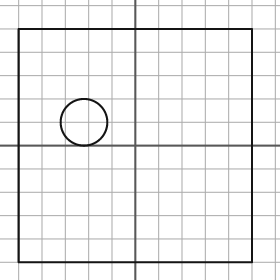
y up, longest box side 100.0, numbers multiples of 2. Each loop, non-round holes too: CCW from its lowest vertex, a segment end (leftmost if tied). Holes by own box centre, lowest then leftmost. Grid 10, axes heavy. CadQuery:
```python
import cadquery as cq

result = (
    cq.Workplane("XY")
    .moveTo(-50.0, -50.0)
    .lineTo(50.0, -50.0)
    .lineTo(50.0, 50.0)
    .lineTo(-50.0, 50.0)
    .close()
    .moveTo(-22.0, 10.0)
    .circle(10.0)
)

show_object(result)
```